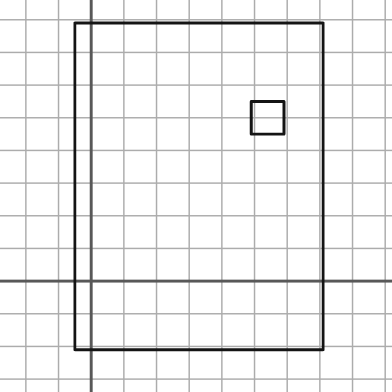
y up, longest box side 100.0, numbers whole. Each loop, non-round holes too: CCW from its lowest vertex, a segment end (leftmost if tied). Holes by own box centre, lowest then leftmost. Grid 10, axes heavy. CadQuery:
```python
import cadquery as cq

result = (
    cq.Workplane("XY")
    .moveTo(-5.0, -21.0)
    .lineTo(71.0, -21.0)
    .lineTo(71.0, 79.0)
    .lineTo(-5.0, 79.0)
    .close()
    .moveTo(49.0, 45.0)
    .lineTo(59.0, 45.0)
    .lineTo(59.0, 55.0)
    .lineTo(49.0, 55.0)
    .close()
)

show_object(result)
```